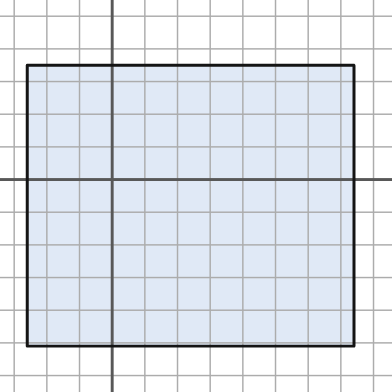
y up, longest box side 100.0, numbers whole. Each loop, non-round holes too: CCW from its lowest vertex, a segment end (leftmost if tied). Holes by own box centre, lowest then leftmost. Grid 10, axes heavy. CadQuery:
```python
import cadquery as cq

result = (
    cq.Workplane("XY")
    .moveTo(-26.0, -51.0)
    .lineTo(74.0, -51.0)
    .lineTo(74.0, 35.0)
    .lineTo(-26.0, 35.0)
    .close()
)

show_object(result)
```